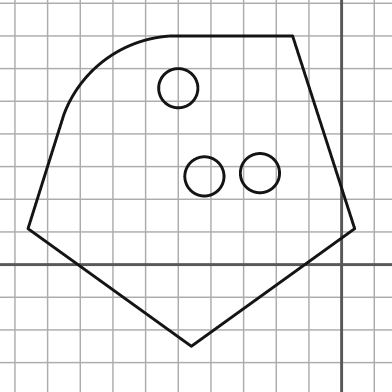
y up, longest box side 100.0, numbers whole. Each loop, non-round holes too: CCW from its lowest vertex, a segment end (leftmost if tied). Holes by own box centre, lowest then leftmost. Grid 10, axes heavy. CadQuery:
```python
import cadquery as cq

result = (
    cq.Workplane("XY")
    .moveTo(-46.0, -25.0)
    .lineTo(4.0, 11.0)
    .lineTo(-15.0, 70.0)
    .lineTo(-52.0, 70.0)
    .threePointArc((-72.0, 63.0), (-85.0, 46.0))
    .lineTo(-96.0, 11.0)
    .close()
    .moveTo(-42.0, 27.0)
    .circle(6.0)
    .moveTo(-25.0, 28.0)
    .circle(6.0)
    .moveTo(-50.0, 54.0)
    .circle(6.0)
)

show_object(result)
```